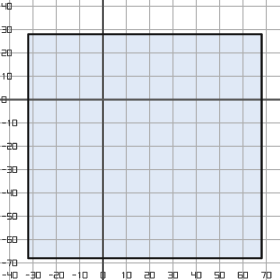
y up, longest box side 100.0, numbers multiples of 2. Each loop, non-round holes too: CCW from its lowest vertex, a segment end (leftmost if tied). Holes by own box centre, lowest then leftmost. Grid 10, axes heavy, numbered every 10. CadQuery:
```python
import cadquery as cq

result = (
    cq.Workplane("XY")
    .moveTo(-32.0, -68.0)
    .lineTo(68.0, -68.0)
    .lineTo(68.0, 28.0)
    .lineTo(-32.0, 28.0)
    .close()
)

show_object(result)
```